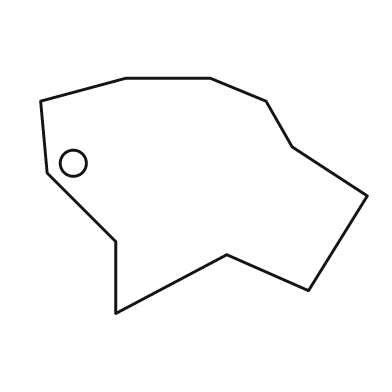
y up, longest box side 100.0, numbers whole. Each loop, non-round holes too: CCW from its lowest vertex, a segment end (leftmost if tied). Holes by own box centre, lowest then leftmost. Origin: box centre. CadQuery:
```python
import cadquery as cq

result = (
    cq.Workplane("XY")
    .moveTo(-27.0, -36.0)
    .lineTo(7.0, -18.0)
    .lineTo(32.0, -29.0)
    .lineTo(50.0, 0.0)
    .lineTo(27.0, 15.0)
    .lineTo(19.0, 29.0)
    .lineTo(2.0, 36.0)
    .lineTo(-24.0, 36.0)
    .lineTo(-50.0, 29.0)
    .lineTo(-48.0, 7.0)
    .lineTo(-27.0, -14.0)
    .close()
    .moveTo(-40.0, 10.0)
    .circle(4.0)
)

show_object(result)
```